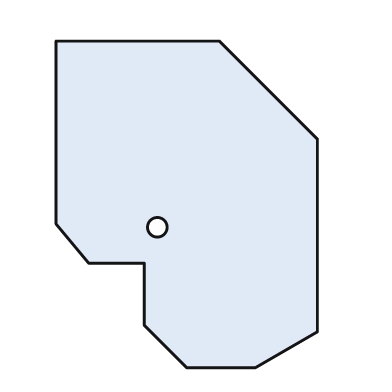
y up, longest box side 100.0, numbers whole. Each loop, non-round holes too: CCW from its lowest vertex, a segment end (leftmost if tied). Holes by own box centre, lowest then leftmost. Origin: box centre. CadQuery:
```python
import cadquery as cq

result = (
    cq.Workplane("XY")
    .moveTo(0.0, -50.0)
    .lineTo(21.0, -50.0)
    .lineTo(40.0, -39.0)
    .lineTo(40.0, 20.0)
    .lineTo(10.0, 50.0)
    .lineTo(-40.0, 50.0)
    .lineTo(-40.0, -6.0)
    .lineTo(-30.0, -18.0)
    .lineTo(-13.0, -18.0)
    .lineTo(-13.0, -37.0)
    .close()
    .moveTo(-9.0, -7.0)
    .circle(3.0)
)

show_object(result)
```